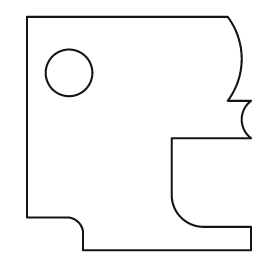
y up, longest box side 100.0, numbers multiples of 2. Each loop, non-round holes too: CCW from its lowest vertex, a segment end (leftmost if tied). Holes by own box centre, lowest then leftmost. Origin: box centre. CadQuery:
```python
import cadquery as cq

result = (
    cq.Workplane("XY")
    .moveTo(-24.0, -50.0)
    .lineTo(48.0, -50.0)
    .lineTo(48.0, -40.0)
    .lineTo(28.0, -40.0)
    .threePointArc((18.0, -36.0), (14.0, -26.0))
    .lineTo(14.0, -2.0)
    .lineTo(48.0, -2.0)
    .threePointArc((44.0, 6.0), (48.0, 14.0))
    .lineTo(38.0, 14.0)
    .threePointArc((44.0, 32.0), (38.0, 50.0))
    .lineTo(-48.0, 50.0)
    .lineTo(-48.0, -36.0)
    .lineTo(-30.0, -36.0)
    .threePointArc((-26.0, -38.0), (-24.0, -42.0))
    .close()
    .moveTo(-30.0, 26.0)
    .circle(10.0)
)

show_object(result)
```